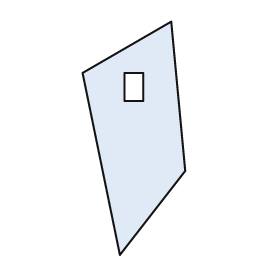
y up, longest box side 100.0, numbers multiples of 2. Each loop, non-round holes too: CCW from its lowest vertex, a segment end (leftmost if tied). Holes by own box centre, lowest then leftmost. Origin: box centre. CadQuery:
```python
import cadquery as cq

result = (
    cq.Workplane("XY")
    .moveTo(-6.0, -50.0)
    .lineTo(22.0, -14.0)
    .lineTo(16.0, 50.0)
    .lineTo(-22.0, 28.0)
    .close()
    .moveTo(-4.0, 16.0)
    .lineTo(4.0, 16.0)
    .lineTo(4.0, 28.0)
    .lineTo(-4.0, 28.0)
    .close()
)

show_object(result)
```